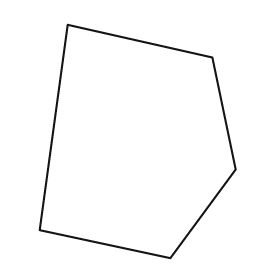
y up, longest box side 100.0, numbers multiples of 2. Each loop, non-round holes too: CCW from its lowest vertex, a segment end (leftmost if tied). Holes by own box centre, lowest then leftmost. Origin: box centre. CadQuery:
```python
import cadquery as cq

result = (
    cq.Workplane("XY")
    .moveTo(14.0, -50.0)
    .lineTo(42.0, -12.0)
    .lineTo(32.0, 36.0)
    .lineTo(-30.0, 50.0)
    .lineTo(-42.0, -38.0)
    .close()
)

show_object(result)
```